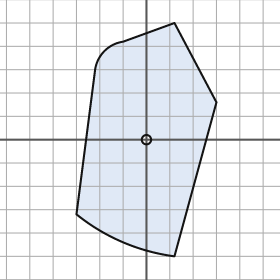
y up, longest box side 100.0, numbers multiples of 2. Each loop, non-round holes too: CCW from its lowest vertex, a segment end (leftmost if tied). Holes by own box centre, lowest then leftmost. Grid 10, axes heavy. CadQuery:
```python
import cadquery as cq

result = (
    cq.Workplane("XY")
    .moveTo(12.0, -50.0)
    .lineTo(30.0, 16.0)
    .lineTo(12.0, 50.0)
    .lineTo(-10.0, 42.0)
    .threePointArc((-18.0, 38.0), (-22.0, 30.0))
    .lineTo(-30.0, -32.0)
    .threePointArc((-10.0, -44.0), (12.0, -50.0))
    .close()
    .moveTo(0.0, 0.0)
    .circle(2.0)
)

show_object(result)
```